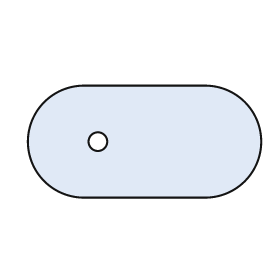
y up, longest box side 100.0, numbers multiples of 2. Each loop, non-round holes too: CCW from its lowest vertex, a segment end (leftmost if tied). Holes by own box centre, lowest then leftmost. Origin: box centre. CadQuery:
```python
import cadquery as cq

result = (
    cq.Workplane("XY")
    .moveTo(-26.0, -24.0)
    .lineTo(26.0, -24.0)
    .threePointArc((50.0, 0.0), (26.0, 24.0))
    .lineTo(-26.0, 24.0)
    .threePointArc((-50.0, 0.0), (-26.0, -24.0))
    .close()
    .moveTo(-20.0, 0.0)
    .circle(4.0)
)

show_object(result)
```